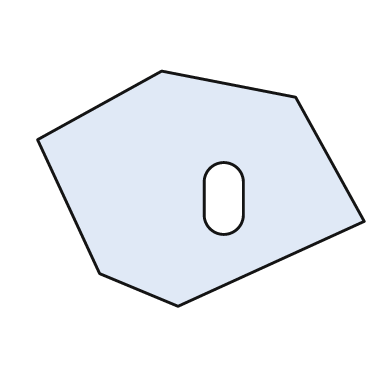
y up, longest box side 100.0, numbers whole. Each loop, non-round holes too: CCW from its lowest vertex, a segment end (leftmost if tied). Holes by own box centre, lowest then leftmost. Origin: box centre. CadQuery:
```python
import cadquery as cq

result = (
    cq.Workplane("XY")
    .moveTo(-7.0, -36.0)
    .lineTo(50.0, -10.0)
    .lineTo(29.0, 28.0)
    .lineTo(-12.0, 36.0)
    .lineTo(-50.0, 15.0)
    .lineTo(-31.0, -26.0)
    .close()
    .moveTo(1.0, -8.0)
    .threePointArc((7.0, -14.0), (13.0, -8.0))
    .lineTo(13.0, 2.0)
    .threePointArc((7.0, 8.0), (1.0, 2.0))
    .close()
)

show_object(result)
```